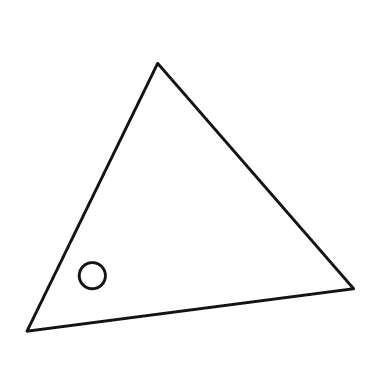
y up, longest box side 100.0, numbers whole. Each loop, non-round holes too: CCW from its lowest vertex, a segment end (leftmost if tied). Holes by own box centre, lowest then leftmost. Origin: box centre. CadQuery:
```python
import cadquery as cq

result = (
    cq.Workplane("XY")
    .moveTo(-50.0, -41.0)
    .lineTo(50.0, -28.0)
    .lineTo(-10.0, 41.0)
    .close()
    .moveTo(-30.0, -24.0)
    .circle(4.0)
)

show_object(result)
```